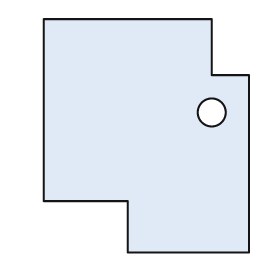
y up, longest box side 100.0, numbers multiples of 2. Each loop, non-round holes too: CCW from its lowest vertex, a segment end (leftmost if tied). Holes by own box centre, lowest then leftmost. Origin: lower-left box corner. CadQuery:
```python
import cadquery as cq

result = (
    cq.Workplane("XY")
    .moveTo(36.0, 0.0)
    .lineTo(88.0, 0.0)
    .lineTo(88.0, 76.0)
    .lineTo(72.0, 76.0)
    .lineTo(72.0, 100.0)
    .lineTo(0.0, 100.0)
    .lineTo(0.0, 22.0)
    .lineTo(36.0, 22.0)
    .close()
    .moveTo(72.0, 60.0)
    .circle(6.0)
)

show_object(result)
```